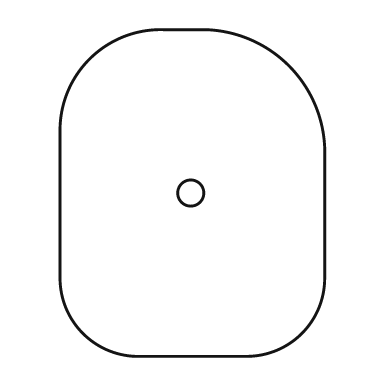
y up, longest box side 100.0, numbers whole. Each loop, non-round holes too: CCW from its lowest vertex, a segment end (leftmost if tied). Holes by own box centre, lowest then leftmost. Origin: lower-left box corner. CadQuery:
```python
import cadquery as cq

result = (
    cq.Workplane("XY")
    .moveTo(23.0, 0.0)
    .lineTo(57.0, 0.0)
    .threePointArc((74.0, 7.0), (81.0, 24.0))
    .lineTo(81.0, 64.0)
    .threePointArc((70.0, 89.0), (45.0, 100.0))
    .lineTo(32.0, 100.0)
    .threePointArc((9.0, 91.0), (0.0, 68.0))
    .lineTo(0.0, 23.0)
    .threePointArc((7.0, 7.0), (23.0, 0.0))
    .close()
    .moveTo(40.0, 50.0)
    .circle(4.0)
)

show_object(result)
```